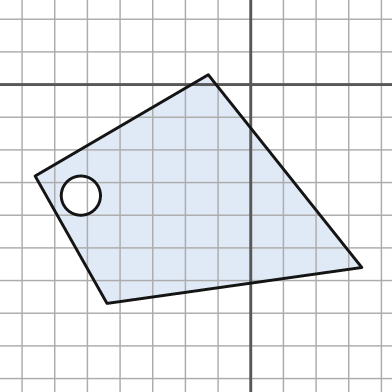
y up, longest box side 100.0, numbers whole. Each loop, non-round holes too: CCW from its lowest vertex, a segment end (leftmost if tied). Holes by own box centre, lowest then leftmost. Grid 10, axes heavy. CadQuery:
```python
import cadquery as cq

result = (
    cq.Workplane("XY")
    .moveTo(-44.0, -67.0)
    .lineTo(34.0, -56.0)
    .lineTo(-13.0, 3.0)
    .lineTo(-66.0, -28.0)
    .close()
    .moveTo(-52.0, -34.0)
    .circle(6.0)
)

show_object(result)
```